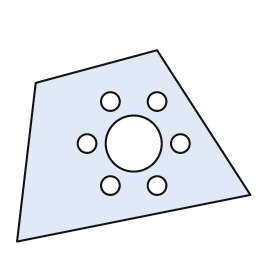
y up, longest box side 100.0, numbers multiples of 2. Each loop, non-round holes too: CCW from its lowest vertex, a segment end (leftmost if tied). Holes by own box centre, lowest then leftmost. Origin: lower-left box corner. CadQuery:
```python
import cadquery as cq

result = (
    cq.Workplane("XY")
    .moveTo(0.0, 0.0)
    .lineTo(100.0, 20.0)
    .lineTo(60.0, 82.0)
    .lineTo(8.0, 68.0)
    .close()
    .moveTo(40.0, 24.0)
    .circle(4.0)
    .moveTo(60.0, 24.0)
    .circle(4.0)
    .moveTo(30.0, 42.0)
    .circle(4.0)
    .moveTo(50.0, 42.0)
    .circle(12.0)
    .moveTo(70.0, 42.0)
    .circle(4.0)
    .moveTo(40.0, 60.0)
    .circle(4.0)
    .moveTo(60.0, 60.0)
    .circle(4.0)
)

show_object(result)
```